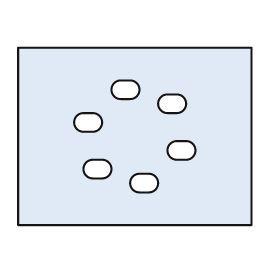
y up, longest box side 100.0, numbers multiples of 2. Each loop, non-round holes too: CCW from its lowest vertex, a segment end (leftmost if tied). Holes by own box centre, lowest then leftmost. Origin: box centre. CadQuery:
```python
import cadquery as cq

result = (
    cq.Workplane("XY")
    .moveTo(-50.0, -38.0)
    .lineTo(50.0, -38.0)
    .lineTo(50.0, 38.0)
    .lineTo(-50.0, 38.0)
    .close()
    .moveTo(2.0, -24.0)
    .lineTo(6.0, -24.0)
    .threePointArc((10.0, -20.0), (6.0, -16.0))
    .lineTo(2.0, -16.0)
    .threePointArc((-2.0, -20.0), (2.0, -24.0))
    .close()
    .moveTo(-18.0, -18.0)
    .lineTo(-14.0, -18.0)
    .threePointArc((-10.0, -14.0), (-14.0, -10.0))
    .lineTo(-18.0, -10.0)
    .threePointArc((-22.0, -14.0), (-18.0, -18.0))
    .close()
    .moveTo(18.0, -10.0)
    .lineTo(22.0, -10.0)
    .threePointArc((26.0, -6.0), (22.0, -2.0))
    .lineTo(18.0, -2.0)
    .threePointArc((14.0, -6.0), (18.0, -10.0))
    .close()
    .moveTo(-22.0, 2.0)
    .lineTo(-18.0, 2.0)
    .threePointArc((-14.0, 6.0), (-18.0, 10.0))
    .lineTo(-22.0, 10.0)
    .threePointArc((-26.0, 6.0), (-22.0, 2.0))
    .close()
    .moveTo(14.0, 10.0)
    .lineTo(18.0, 10.0)
    .threePointArc((22.0, 14.0), (18.0, 18.0))
    .lineTo(14.0, 18.0)
    .threePointArc((10.0, 14.0), (14.0, 10.0))
    .close()
    .moveTo(-6.0, 16.0)
    .lineTo(-2.0, 16.0)
    .threePointArc((2.0, 20.0), (-2.0, 24.0))
    .lineTo(-6.0, 24.0)
    .threePointArc((-10.0, 20.0), (-6.0, 16.0))
    .close()
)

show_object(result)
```